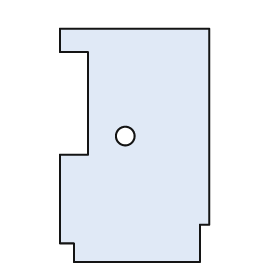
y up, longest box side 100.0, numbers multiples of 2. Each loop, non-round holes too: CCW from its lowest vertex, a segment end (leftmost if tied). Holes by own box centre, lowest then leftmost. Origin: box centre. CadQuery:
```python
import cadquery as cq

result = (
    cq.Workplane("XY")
    .moveTo(-26.0, -50.0)
    .lineTo(28.0, -50.0)
    .lineTo(28.0, -34.0)
    .lineTo(32.0, -34.0)
    .lineTo(32.0, 50.0)
    .lineTo(-32.0, 50.0)
    .lineTo(-32.0, 40.0)
    .lineTo(-20.0, 40.0)
    .lineTo(-20.0, -4.0)
    .lineTo(-32.0, -4.0)
    .lineTo(-32.0, -42.0)
    .lineTo(-26.0, -42.0)
    .close()
    .moveTo(-4.0, 4.0)
    .circle(4.0)
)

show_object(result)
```